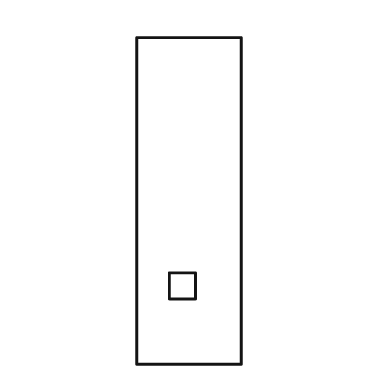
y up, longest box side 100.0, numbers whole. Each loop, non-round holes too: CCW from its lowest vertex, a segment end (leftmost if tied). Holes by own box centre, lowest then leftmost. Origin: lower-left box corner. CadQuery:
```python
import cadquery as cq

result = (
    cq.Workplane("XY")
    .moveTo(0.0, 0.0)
    .lineTo(32.0, 0.0)
    .lineTo(32.0, 100.0)
    .lineTo(0.0, 100.0)
    .close()
    .moveTo(10.0, 20.0)
    .lineTo(18.0, 20.0)
    .lineTo(18.0, 28.0)
    .lineTo(10.0, 28.0)
    .close()
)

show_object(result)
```